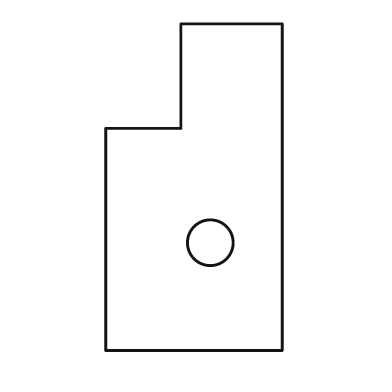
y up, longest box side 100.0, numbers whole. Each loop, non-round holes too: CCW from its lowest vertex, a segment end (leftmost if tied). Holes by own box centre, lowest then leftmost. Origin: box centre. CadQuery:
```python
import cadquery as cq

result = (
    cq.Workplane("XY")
    .moveTo(-27.0, -50.0)
    .lineTo(27.0, -50.0)
    .lineTo(27.0, 50.0)
    .lineTo(-4.0, 50.0)
    .lineTo(-4.0, 18.0)
    .lineTo(-27.0, 18.0)
    .close()
    .moveTo(5.0, -17.0)
    .circle(7.0)
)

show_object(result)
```